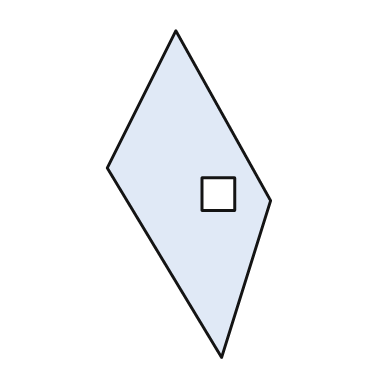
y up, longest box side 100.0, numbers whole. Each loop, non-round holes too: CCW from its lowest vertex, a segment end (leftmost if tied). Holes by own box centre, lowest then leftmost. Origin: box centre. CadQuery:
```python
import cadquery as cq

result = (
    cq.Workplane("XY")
    .moveTo(10.0, -50.0)
    .lineTo(25.0, -2.0)
    .lineTo(-4.0, 50.0)
    .lineTo(-25.0, 8.0)
    .close()
    .moveTo(4.0, -5.0)
    .lineTo(14.0, -5.0)
    .lineTo(14.0, 5.0)
    .lineTo(4.0, 5.0)
    .close()
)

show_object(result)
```